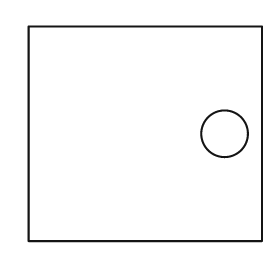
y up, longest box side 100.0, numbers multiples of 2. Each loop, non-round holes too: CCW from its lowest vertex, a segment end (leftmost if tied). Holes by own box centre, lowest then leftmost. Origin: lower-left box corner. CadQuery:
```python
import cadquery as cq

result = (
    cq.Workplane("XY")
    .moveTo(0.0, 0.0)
    .lineTo(100.0, 0.0)
    .lineTo(100.0, 92.0)
    .lineTo(0.0, 92.0)
    .close()
    .moveTo(84.0, 46.0)
    .circle(10.0)
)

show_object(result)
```